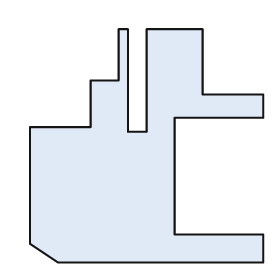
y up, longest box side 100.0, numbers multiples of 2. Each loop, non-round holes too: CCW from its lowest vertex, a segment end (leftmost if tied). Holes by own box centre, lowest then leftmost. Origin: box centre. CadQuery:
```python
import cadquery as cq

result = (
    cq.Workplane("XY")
    .moveTo(-38.0, -50.0)
    .lineTo(50.0, -50.0)
    .lineTo(50.0, -38.0)
    .lineTo(12.0, -38.0)
    .lineTo(12.0, 12.0)
    .lineTo(50.0, 12.0)
    .lineTo(50.0, 22.0)
    .lineTo(24.0, 22.0)
    .lineTo(24.0, 50.0)
    .lineTo(0.0, 50.0)
    .lineTo(0.0, 6.0)
    .lineTo(-8.0, 6.0)
    .lineTo(-8.0, 50.0)
    .lineTo(-12.0, 50.0)
    .lineTo(-12.0, 28.0)
    .lineTo(-24.0, 28.0)
    .lineTo(-24.0, 8.0)
    .lineTo(-50.0, 8.0)
    .lineTo(-50.0, -42.0)
    .close()
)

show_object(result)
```